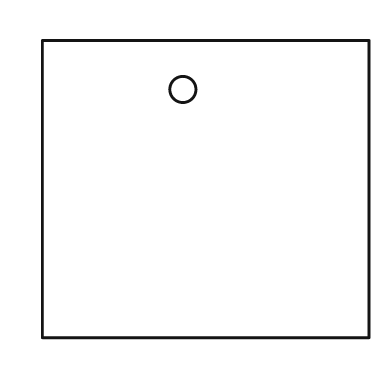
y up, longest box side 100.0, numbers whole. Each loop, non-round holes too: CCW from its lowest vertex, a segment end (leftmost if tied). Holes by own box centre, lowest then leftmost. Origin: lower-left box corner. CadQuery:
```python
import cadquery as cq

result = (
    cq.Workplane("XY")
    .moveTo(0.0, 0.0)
    .lineTo(100.0, 0.0)
    .lineTo(100.0, 91.0)
    .lineTo(0.0, 91.0)
    .close()
    .moveTo(43.0, 76.0)
    .circle(4.0)
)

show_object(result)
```